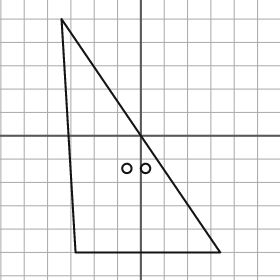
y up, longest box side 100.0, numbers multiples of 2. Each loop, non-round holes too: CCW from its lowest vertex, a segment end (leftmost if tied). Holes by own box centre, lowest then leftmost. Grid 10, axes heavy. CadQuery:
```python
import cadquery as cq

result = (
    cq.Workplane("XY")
    .moveTo(-28.0, -50.0)
    .lineTo(34.0, -50.0)
    .lineTo(-34.0, 50.0)
    .close()
    .moveTo(-6.0, -14.0)
    .circle(2.0)
    .moveTo(2.0, -14.0)
    .circle(2.0)
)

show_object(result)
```